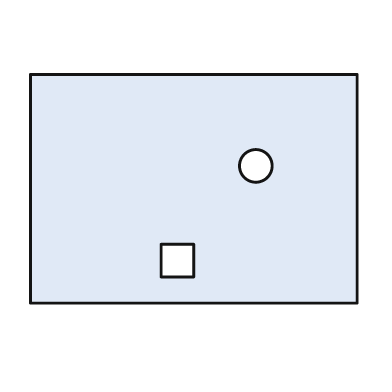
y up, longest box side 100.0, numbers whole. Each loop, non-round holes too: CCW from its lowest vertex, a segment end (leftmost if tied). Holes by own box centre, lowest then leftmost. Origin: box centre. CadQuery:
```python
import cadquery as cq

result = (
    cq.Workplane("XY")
    .moveTo(-50.0, -35.0)
    .lineTo(50.0, -35.0)
    .lineTo(50.0, 35.0)
    .lineTo(-50.0, 35.0)
    .close()
    .moveTo(-10.0, -27.0)
    .lineTo(0.0, -27.0)
    .lineTo(0.0, -17.0)
    .lineTo(-10.0, -17.0)
    .close()
    .moveTo(19.0, 7.0)
    .circle(5.0)
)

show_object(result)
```